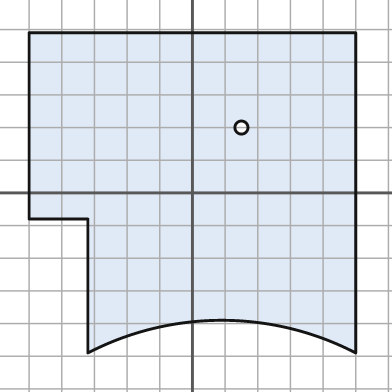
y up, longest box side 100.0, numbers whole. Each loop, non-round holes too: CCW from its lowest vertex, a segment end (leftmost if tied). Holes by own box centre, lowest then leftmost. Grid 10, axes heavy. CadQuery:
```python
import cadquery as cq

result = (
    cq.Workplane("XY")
    .moveTo(-32.0, -49.0)
    .threePointArc((9.0, -39.0), (50.0, -49.0))
    .lineTo(50.0, 49.0)
    .lineTo(-50.0, 49.0)
    .lineTo(-50.0, -8.0)
    .lineTo(-32.0, -8.0)
    .close()
    .moveTo(15.0, 20.0)
    .circle(2.0)
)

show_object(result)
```